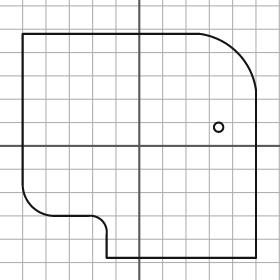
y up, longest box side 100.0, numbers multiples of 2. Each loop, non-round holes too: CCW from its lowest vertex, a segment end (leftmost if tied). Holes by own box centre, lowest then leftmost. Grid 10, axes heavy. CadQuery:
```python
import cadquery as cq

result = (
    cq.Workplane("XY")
    .moveTo(-14.0, -48.0)
    .lineTo(50.0, -48.0)
    .lineTo(50.0, 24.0)
    .threePointArc((42.0, 40.0), (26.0, 48.0))
    .lineTo(-50.0, 48.0)
    .lineTo(-50.0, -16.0)
    .threePointArc((-46.0, -26.0), (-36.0, -30.0))
    .lineTo(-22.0, -30.0)
    .threePointArc((-16.0, -32.0), (-14.0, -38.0))
    .close()
    .moveTo(34.0, 8.0)
    .circle(2.0)
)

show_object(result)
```